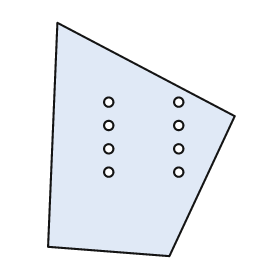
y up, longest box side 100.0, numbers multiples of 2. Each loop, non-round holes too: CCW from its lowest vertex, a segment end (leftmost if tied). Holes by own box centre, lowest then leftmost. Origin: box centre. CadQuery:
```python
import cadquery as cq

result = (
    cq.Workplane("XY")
    .moveTo(12.0, -50.0)
    .lineTo(40.0, 10.0)
    .lineTo(-36.0, 50.0)
    .lineTo(-40.0, -46.0)
    .close()
    .moveTo(-14.0, -14.0)
    .circle(2.0)
    .moveTo(16.0, -14.0)
    .circle(2.0)
    .moveTo(-14.0, -4.0)
    .circle(2.0)
    .moveTo(16.0, -4.0)
    .circle(2.0)
    .moveTo(-14.0, 6.0)
    .circle(2.0)
    .moveTo(16.0, 6.0)
    .circle(2.0)
    .moveTo(-14.0, 16.0)
    .circle(2.0)
    .moveTo(16.0, 16.0)
    .circle(2.0)
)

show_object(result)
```